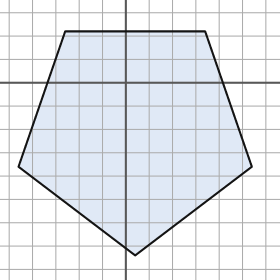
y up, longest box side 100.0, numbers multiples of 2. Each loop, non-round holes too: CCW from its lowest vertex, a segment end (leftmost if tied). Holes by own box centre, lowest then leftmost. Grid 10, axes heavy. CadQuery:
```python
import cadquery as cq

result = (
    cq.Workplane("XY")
    .moveTo(4.0, -74.0)
    .lineTo(54.0, -36.0)
    .lineTo(34.0, 22.0)
    .lineTo(-26.0, 22.0)
    .lineTo(-46.0, -36.0)
    .close()
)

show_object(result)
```